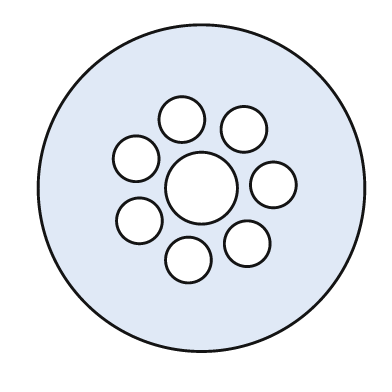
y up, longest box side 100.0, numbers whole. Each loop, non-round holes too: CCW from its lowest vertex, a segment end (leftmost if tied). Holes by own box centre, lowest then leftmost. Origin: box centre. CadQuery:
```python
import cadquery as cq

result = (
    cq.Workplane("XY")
    .moveTo(0.0, 0.0)
    .circle(50.0)
    .moveTo(-4.0, -22.0)
    .circle(7.0)
    .moveTo(14.0, -17.0)
    .circle(7.0)
    .moveTo(-19.0, -10.0)
    .circle(7.0)
    .moveTo(0.0, 0.0)
    .circle(11.0)
    .moveTo(22.0, 1.0)
    .circle(7.0)
    .moveTo(-20.0, 9.0)
    .circle(7.0)
    .moveTo(13.0, 18.0)
    .circle(7.0)
    .moveTo(-6.0, 21.0)
    .circle(7.0)
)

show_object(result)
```